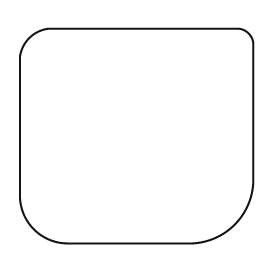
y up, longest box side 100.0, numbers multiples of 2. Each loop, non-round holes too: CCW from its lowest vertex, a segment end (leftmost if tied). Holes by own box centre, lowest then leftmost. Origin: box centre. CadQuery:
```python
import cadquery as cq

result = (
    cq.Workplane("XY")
    .moveTo(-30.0, -46.0)
    .lineTo(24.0, -46.0)
    .threePointArc((42.0, -38.0), (50.0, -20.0))
    .lineTo(50.0, 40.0)
    .threePointArc((48.0, 44.0), (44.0, 46.0))
    .lineTo(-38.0, 46.0)
    .threePointArc((-46.0, 42.0), (-50.0, 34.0))
    .lineTo(-50.0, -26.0)
    .threePointArc((-44.0, -40.0), (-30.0, -46.0))
    .close()
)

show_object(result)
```